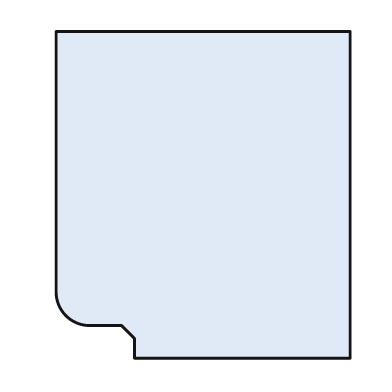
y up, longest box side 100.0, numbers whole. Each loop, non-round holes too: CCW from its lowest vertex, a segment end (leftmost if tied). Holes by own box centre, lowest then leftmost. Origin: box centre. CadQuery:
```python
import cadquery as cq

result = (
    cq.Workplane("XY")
    .moveTo(-21.0, -50.0)
    .lineTo(45.0, -50.0)
    .lineTo(45.0, 50.0)
    .lineTo(-45.0, 50.0)
    .lineTo(-45.0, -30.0)
    .threePointArc((-42.0, -37.0), (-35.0, -40.0))
    .lineTo(-25.0, -40.0)
    .lineTo(-21.0, -44.0)
    .close()
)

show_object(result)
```